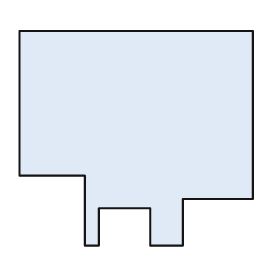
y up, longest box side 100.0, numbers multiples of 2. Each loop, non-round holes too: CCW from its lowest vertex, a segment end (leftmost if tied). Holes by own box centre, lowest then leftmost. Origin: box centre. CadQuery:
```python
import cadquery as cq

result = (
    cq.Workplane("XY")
    .moveTo(-22.0, -46.0)
    .lineTo(-16.0, -46.0)
    .lineTo(-16.0, -30.0)
    .lineTo(6.0, -30.0)
    .lineTo(6.0, -46.0)
    .lineTo(20.0, -46.0)
    .lineTo(20.0, -26.0)
    .lineTo(50.0, -26.0)
    .lineTo(50.0, 46.0)
    .lineTo(-50.0, 46.0)
    .lineTo(-50.0, -16.0)
    .lineTo(-22.0, -16.0)
    .close()
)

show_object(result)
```